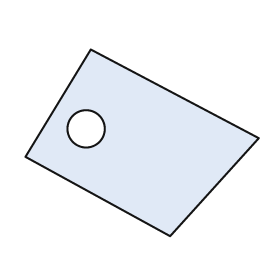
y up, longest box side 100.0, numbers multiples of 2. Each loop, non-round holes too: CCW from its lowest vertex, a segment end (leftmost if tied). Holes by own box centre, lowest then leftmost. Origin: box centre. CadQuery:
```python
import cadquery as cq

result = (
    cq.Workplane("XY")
    .moveTo(12.0, -40.0)
    .lineTo(50.0, 2.0)
    .lineTo(-22.0, 40.0)
    .lineTo(-50.0, -6.0)
    .close()
    .moveTo(-24.0, 6.0)
    .circle(8.0)
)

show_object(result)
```